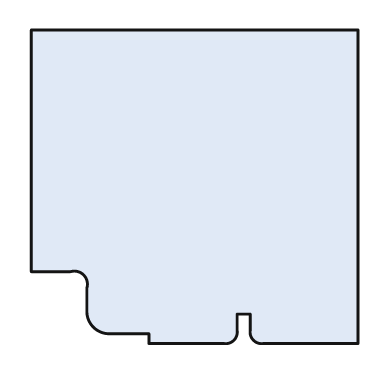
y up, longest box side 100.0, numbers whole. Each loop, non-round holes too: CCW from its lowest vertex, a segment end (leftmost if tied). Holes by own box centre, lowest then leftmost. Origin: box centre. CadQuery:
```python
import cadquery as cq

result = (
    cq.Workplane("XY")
    .moveTo(-14.0, -48.0)
    .lineTo(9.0, -48.0)
    .threePointArc((12.0, -47.0), (13.0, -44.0))
    .lineTo(13.0, -39.0)
    .lineTo(17.0, -39.0)
    .lineTo(17.0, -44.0)
    .threePointArc((18.0, -47.0), (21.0, -48.0))
    .lineTo(50.0, -48.0)
    .lineTo(50.0, 48.0)
    .lineTo(-50.0, 48.0)
    .lineTo(-50.0, -26.0)
    .lineTo(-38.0, -26.0)
    .threePointArc((-34.0, -27.0), (-33.0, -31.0))
    .lineTo(-33.0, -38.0)
    .threePointArc((-31.0, -43.0), (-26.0, -45.0))
    .lineTo(-14.0, -45.0)
    .close()
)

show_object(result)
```